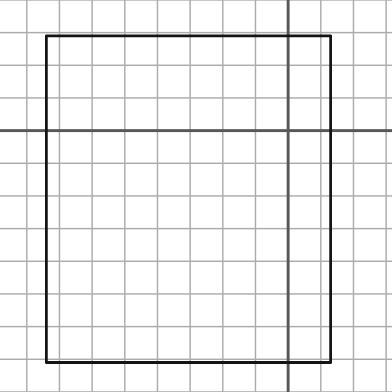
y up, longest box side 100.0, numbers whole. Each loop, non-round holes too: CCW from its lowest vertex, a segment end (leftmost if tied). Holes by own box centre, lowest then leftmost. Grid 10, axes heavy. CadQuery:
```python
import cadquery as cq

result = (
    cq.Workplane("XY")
    .moveTo(-74.0, -71.0)
    .lineTo(13.0, -71.0)
    .lineTo(13.0, 29.0)
    .lineTo(-74.0, 29.0)
    .close()
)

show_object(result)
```